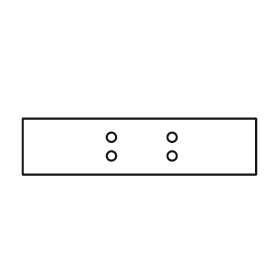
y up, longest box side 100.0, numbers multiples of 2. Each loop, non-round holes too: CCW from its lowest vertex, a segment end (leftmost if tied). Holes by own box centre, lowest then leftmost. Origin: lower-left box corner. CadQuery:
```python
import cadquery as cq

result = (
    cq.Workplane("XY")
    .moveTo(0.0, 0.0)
    .lineTo(100.0, 0.0)
    .lineTo(100.0, 24.0)
    .lineTo(0.0, 24.0)
    .close()
    .moveTo(38.0, 8.0)
    .circle(2.0)
    .moveTo(64.0, 8.0)
    .circle(2.0)
    .moveTo(38.0, 16.0)
    .circle(2.0)
    .moveTo(64.0, 16.0)
    .circle(2.0)
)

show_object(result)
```